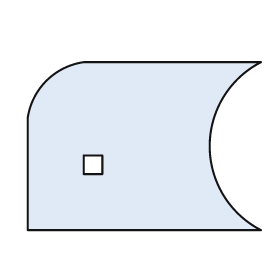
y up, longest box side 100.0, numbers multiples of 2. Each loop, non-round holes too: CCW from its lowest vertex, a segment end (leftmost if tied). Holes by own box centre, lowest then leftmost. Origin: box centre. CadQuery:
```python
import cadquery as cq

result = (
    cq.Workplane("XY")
    .moveTo(-50.0, -36.0)
    .lineTo(50.0, -36.0)
    .threePointArc((28.0, 0.0), (50.0, 36.0))
    .lineTo(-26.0, 36.0)
    .threePointArc((-42.0, 28.0), (-50.0, 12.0))
    .close()
    .moveTo(-26.0, -12.0)
    .lineTo(-18.0, -12.0)
    .lineTo(-18.0, -4.0)
    .lineTo(-26.0, -4.0)
    .close()
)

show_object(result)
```